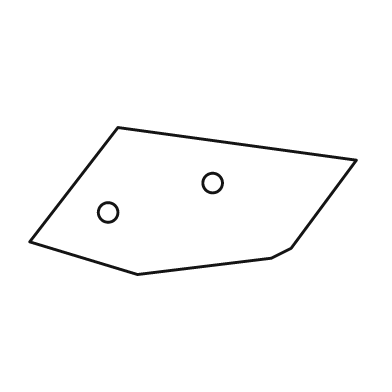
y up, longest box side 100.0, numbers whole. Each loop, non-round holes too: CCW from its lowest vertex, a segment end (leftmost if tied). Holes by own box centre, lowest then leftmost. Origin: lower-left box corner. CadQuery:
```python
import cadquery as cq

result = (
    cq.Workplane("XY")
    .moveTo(33.0, 0.0)
    .lineTo(74.0, 5.0)
    .lineTo(80.0, 8.0)
    .lineTo(100.0, 35.0)
    .lineTo(27.0, 45.0)
    .lineTo(0.0, 10.0)
    .close()
    .moveTo(24.0, 19.0)
    .circle(3.0)
    .moveTo(56.0, 28.0)
    .circle(3.0)
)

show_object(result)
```